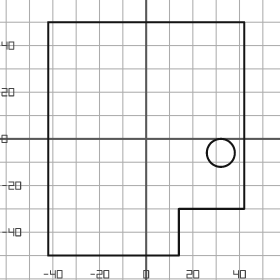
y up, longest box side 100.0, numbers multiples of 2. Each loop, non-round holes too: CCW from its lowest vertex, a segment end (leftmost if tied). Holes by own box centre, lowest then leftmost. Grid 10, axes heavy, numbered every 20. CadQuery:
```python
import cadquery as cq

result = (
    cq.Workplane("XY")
    .moveTo(-42.0, -50.0)
    .lineTo(14.0, -50.0)
    .lineTo(14.0, -30.0)
    .lineTo(42.0, -30.0)
    .lineTo(42.0, 50.0)
    .lineTo(-42.0, 50.0)
    .close()
    .moveTo(32.0, -6.0)
    .circle(6.0)
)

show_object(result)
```